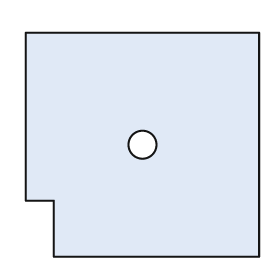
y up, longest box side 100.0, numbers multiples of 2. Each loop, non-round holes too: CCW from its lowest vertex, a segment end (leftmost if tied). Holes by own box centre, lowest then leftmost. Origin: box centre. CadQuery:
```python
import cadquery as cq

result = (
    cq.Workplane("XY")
    .moveTo(-38.0, -48.0)
    .lineTo(50.0, -48.0)
    .lineTo(50.0, 48.0)
    .lineTo(-50.0, 48.0)
    .lineTo(-50.0, -24.0)
    .lineTo(-38.0, -24.0)
    .close()
    .moveTo(0.0, 0.0)
    .circle(6.0)
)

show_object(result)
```